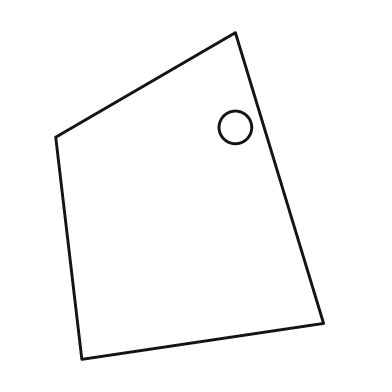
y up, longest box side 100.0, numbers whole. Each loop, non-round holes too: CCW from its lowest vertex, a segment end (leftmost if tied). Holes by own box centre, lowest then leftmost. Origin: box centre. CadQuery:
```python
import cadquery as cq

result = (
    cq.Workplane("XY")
    .moveTo(-33.0, -50.0)
    .lineTo(41.0, -39.0)
    .lineTo(14.0, 50.0)
    .lineTo(-41.0, 18.0)
    .close()
    .moveTo(14.0, 21.0)
    .circle(5.0)
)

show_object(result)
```